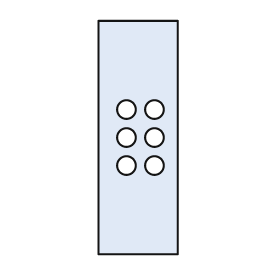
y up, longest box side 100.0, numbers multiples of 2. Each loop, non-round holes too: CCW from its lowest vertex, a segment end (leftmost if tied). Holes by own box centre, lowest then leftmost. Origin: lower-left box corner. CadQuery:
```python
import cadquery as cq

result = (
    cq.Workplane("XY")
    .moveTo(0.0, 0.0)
    .lineTo(34.0, 0.0)
    .lineTo(34.0, 100.0)
    .lineTo(0.0, 100.0)
    .close()
    .moveTo(12.0, 38.0)
    .circle(4.0)
    .moveTo(24.0, 38.0)
    .circle(4.0)
    .moveTo(12.0, 50.0)
    .circle(4.0)
    .moveTo(24.0, 50.0)
    .circle(4.0)
    .moveTo(12.0, 62.0)
    .circle(4.0)
    .moveTo(24.0, 62.0)
    .circle(4.0)
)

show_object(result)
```